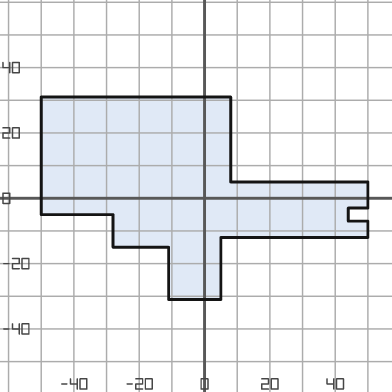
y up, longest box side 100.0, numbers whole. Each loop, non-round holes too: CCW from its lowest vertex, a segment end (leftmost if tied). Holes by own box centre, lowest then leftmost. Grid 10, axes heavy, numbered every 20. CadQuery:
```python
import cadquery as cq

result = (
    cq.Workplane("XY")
    .moveTo(-11.0, -31.0)
    .lineTo(5.0, -31.0)
    .lineTo(5.0, -12.0)
    .lineTo(50.0, -12.0)
    .lineTo(50.0, -7.0)
    .lineTo(44.0, -7.0)
    .lineTo(44.0, -3.0)
    .lineTo(50.0, -3.0)
    .lineTo(50.0, 5.0)
    .lineTo(8.0, 5.0)
    .lineTo(8.0, 31.0)
    .lineTo(-50.0, 31.0)
    .lineTo(-50.0, -5.0)
    .lineTo(-28.0, -5.0)
    .lineTo(-28.0, -15.0)
    .lineTo(-11.0, -15.0)
    .close()
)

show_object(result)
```